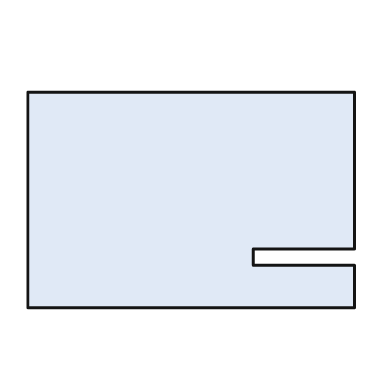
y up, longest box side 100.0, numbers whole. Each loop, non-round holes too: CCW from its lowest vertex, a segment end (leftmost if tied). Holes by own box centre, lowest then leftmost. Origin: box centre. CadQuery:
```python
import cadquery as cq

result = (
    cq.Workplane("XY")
    .moveTo(-50.0, -33.0)
    .lineTo(50.0, -33.0)
    .lineTo(50.0, -20.0)
    .lineTo(19.0, -20.0)
    .lineTo(19.0, -15.0)
    .lineTo(50.0, -15.0)
    .lineTo(50.0, 33.0)
    .lineTo(-50.0, 33.0)
    .close()
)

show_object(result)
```